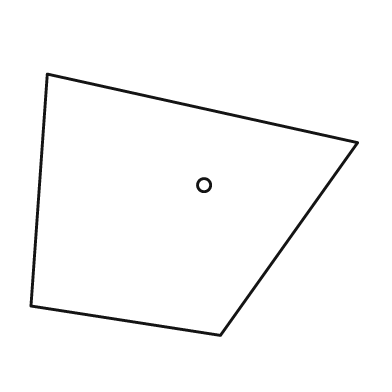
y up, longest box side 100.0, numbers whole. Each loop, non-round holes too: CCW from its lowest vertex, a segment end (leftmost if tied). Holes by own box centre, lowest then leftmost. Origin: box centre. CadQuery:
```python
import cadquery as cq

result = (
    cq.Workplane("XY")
    .moveTo(8.0, -40.0)
    .lineTo(50.0, 19.0)
    .lineTo(-45.0, 40.0)
    .lineTo(-50.0, -31.0)
    .close()
    .moveTo(3.0, 6.0)
    .circle(2.0)
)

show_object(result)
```